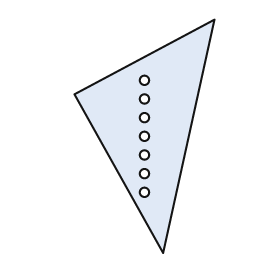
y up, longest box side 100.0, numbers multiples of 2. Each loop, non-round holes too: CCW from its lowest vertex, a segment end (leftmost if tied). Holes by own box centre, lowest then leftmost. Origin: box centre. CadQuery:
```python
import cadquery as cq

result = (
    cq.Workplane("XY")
    .moveTo(8.0, -50.0)
    .lineTo(30.0, 50.0)
    .lineTo(-30.0, 18.0)
    .close()
    .moveTo(0.0, -24.0)
    .circle(2.0)
    .moveTo(0.0, -16.0)
    .circle(2.0)
    .moveTo(0.0, -8.0)
    .circle(2.0)
    .moveTo(0.0, 0.0)
    .circle(2.0)
    .moveTo(0.0, 8.0)
    .circle(2.0)
    .moveTo(0.0, 16.0)
    .circle(2.0)
    .moveTo(0.0, 24.0)
    .circle(2.0)
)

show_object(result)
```